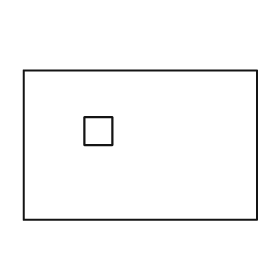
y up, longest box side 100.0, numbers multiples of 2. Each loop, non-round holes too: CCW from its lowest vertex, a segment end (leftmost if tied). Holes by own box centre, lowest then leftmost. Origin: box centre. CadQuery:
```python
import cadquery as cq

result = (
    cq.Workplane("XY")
    .moveTo(-50.0, -32.0)
    .lineTo(50.0, -32.0)
    .lineTo(50.0, 32.0)
    .lineTo(-50.0, 32.0)
    .close()
    .moveTo(-24.0, 0.0)
    .lineTo(-12.0, 0.0)
    .lineTo(-12.0, 12.0)
    .lineTo(-24.0, 12.0)
    .close()
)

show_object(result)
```